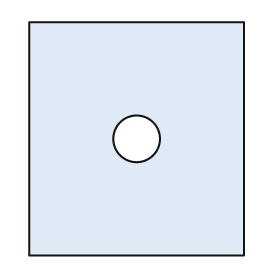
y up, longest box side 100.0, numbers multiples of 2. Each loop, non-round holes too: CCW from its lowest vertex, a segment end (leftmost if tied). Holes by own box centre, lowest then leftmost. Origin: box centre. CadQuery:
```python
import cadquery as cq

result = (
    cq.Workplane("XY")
    .moveTo(-46.0, -50.0)
    .lineTo(46.0, -50.0)
    .lineTo(46.0, 50.0)
    .lineTo(-46.0, 50.0)
    .close()
    .moveTo(0.0, 0.0)
    .circle(10.0)
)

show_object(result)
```